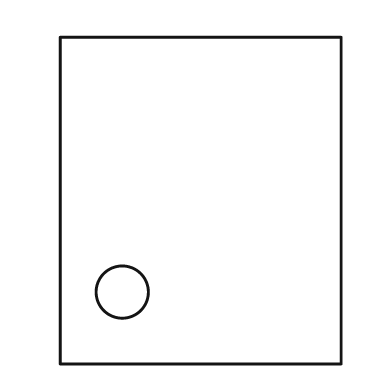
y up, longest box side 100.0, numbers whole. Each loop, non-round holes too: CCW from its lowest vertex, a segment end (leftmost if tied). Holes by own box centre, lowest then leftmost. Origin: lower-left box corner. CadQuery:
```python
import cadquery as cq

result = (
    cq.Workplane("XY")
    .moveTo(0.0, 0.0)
    .lineTo(86.0, 0.0)
    .lineTo(86.0, 100.0)
    .lineTo(0.0, 100.0)
    .close()
    .moveTo(19.0, 22.0)
    .circle(8.0)
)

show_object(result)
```